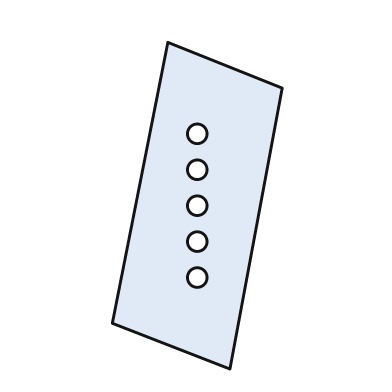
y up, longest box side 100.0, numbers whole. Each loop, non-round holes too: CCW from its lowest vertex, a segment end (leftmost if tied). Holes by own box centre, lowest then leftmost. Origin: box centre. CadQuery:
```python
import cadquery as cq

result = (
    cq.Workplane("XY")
    .moveTo(10.0, -50.0)
    .lineTo(26.0, 36.0)
    .lineTo(-9.0, 50.0)
    .lineTo(-26.0, -36.0)
    .close()
    .moveTo(0.0, -22.0)
    .circle(3.0)
    .moveTo(0.0, -11.0)
    .circle(3.0)
    .moveTo(0.0, 0.0)
    .circle(3.0)
    .moveTo(0.0, 11.0)
    .circle(3.0)
    .moveTo(0.0, 22.0)
    .circle(3.0)
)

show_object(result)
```